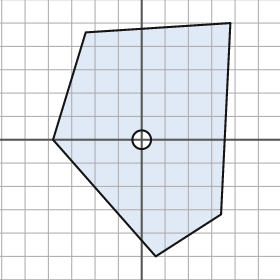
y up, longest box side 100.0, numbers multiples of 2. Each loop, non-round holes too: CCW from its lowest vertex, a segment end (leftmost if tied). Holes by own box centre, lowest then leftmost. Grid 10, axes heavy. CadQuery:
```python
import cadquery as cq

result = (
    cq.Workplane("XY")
    .moveTo(6.0, -50.0)
    .lineTo(34.0, -32.0)
    .lineTo(38.0, 50.0)
    .lineTo(-24.0, 46.0)
    .lineTo(-38.0, 0.0)
    .close()
    .moveTo(0.0, 0.0)
    .circle(4.0)
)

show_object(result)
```